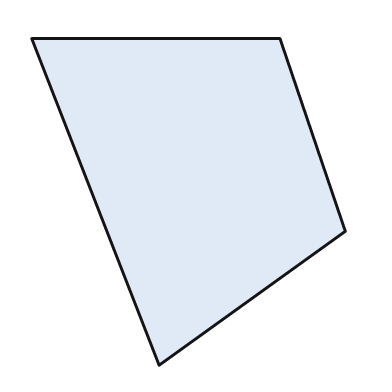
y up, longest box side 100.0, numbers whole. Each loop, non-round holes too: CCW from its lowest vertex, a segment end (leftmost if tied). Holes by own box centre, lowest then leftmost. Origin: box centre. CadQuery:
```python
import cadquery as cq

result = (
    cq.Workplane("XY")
    .moveTo(-9.0, -50.0)
    .lineTo(48.0, -9.0)
    .lineTo(28.0, 50.0)
    .lineTo(-48.0, 50.0)
    .close()
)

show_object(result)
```